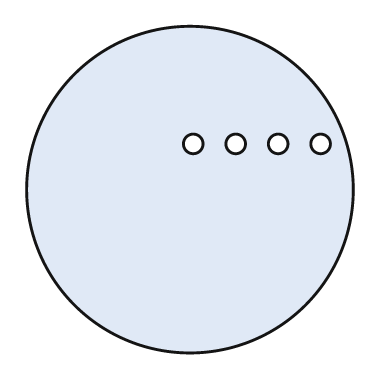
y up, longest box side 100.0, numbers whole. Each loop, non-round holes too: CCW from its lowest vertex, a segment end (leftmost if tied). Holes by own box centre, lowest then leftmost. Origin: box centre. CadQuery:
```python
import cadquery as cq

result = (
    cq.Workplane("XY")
    .moveTo(0.0, 0.0)
    .circle(50.0)
    .moveTo(1.0, 14.0)
    .circle(3.0)
    .moveTo(14.0, 14.0)
    .circle(3.0)
    .moveTo(27.0, 14.0)
    .circle(3.0)
    .moveTo(40.0, 14.0)
    .circle(3.0)
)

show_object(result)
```